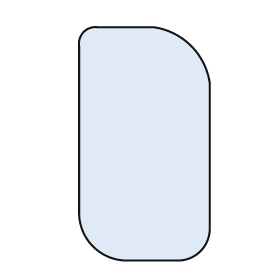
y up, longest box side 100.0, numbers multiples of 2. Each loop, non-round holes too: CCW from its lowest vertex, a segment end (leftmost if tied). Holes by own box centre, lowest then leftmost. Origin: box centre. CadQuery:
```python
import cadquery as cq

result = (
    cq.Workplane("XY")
    .moveTo(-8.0, -50.0)
    .lineTo(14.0, -50.0)
    .threePointArc((24.0, -46.0), (28.0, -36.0))
    .lineTo(28.0, 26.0)
    .threePointArc((20.0, 42.0), (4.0, 50.0))
    .lineTo(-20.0, 50.0)
    .threePointArc((-26.0, 48.0), (-28.0, 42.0))
    .lineTo(-28.0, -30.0)
    .threePointArc((-22.0, -44.0), (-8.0, -50.0))
    .close()
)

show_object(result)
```